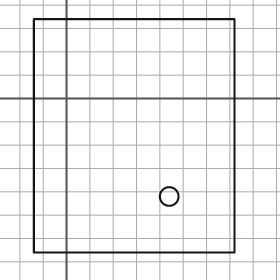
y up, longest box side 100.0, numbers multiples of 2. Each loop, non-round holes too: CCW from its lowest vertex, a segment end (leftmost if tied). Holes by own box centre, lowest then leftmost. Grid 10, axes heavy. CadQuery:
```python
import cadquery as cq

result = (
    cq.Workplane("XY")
    .moveTo(-14.0, -66.0)
    .lineTo(72.0, -66.0)
    .lineTo(72.0, 34.0)
    .lineTo(-14.0, 34.0)
    .close()
    .moveTo(44.0, -42.0)
    .circle(4.0)
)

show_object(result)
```